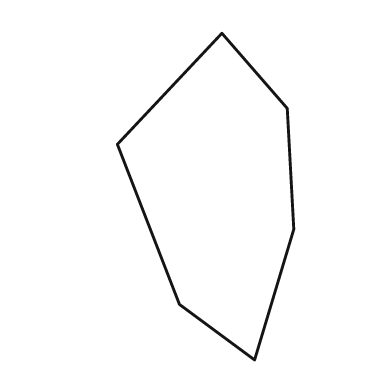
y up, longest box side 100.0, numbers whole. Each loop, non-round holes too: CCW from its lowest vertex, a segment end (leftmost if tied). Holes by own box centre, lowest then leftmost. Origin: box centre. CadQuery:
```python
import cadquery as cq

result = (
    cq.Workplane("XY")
    .moveTo(15.0, -50.0)
    .lineTo(27.0, -10.0)
    .lineTo(25.0, 27.0)
    .lineTo(5.0, 50.0)
    .lineTo(-27.0, 16.0)
    .lineTo(-8.0, -33.0)
    .close()
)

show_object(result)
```